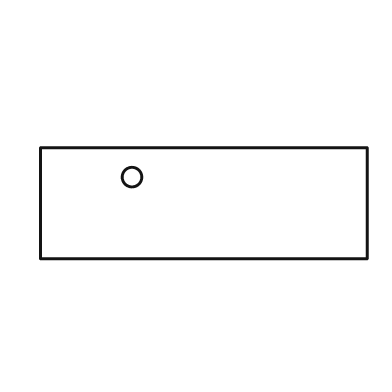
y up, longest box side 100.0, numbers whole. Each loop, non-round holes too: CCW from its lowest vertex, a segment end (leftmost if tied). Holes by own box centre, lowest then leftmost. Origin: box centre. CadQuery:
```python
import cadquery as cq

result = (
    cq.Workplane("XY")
    .moveTo(-50.0, -17.0)
    .lineTo(50.0, -17.0)
    .lineTo(50.0, 17.0)
    .lineTo(-50.0, 17.0)
    .close()
    .moveTo(-22.0, 8.0)
    .circle(3.0)
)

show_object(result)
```